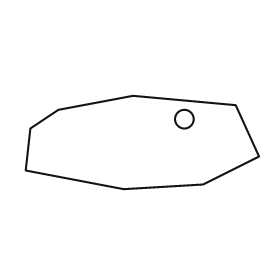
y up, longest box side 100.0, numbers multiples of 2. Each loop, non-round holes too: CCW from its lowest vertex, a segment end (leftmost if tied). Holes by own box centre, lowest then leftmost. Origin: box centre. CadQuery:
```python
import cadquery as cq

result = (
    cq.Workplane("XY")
    .moveTo(-8.0, -20.0)
    .lineTo(26.0, -18.0)
    .lineTo(50.0, -6.0)
    .lineTo(40.0, 16.0)
    .lineTo(-4.0, 20.0)
    .lineTo(-36.0, 14.0)
    .lineTo(-48.0, 6.0)
    .lineTo(-50.0, -12.0)
    .close()
    .moveTo(18.0, 10.0)
    .circle(4.0)
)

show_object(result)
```